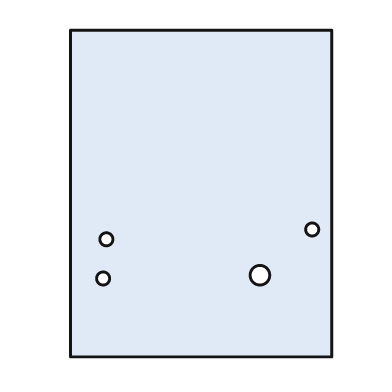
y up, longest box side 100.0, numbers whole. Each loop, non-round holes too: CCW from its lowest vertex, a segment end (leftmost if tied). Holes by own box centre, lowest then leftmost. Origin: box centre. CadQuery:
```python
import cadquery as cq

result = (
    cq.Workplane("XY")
    .moveTo(-40.0, -50.0)
    .lineTo(40.0, -50.0)
    .lineTo(40.0, 50.0)
    .lineTo(-40.0, 50.0)
    .close()
    .moveTo(-30.0, -26.0)
    .circle(2.0)
    .moveTo(18.0, -25.0)
    .circle(3.0)
    .moveTo(-29.0, -14.0)
    .circle(2.0)
    .moveTo(34.0, -11.0)
    .circle(2.0)
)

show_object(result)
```